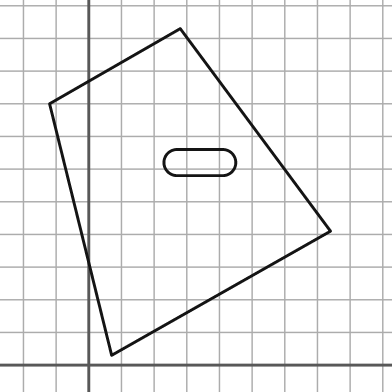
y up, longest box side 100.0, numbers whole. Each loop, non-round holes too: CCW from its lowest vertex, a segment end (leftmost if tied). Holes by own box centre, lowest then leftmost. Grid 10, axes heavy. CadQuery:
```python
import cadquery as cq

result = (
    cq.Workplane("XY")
    .moveTo(7.0, 3.0)
    .lineTo(74.0, 41.0)
    .lineTo(28.0, 103.0)
    .lineTo(-12.0, 80.0)
    .close()
    .moveTo(27.0, 58.0)
    .lineTo(41.0, 58.0)
    .threePointArc((45.0, 62.0), (41.0, 66.0))
    .lineTo(27.0, 66.0)
    .threePointArc((23.0, 62.0), (27.0, 58.0))
    .close()
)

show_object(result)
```